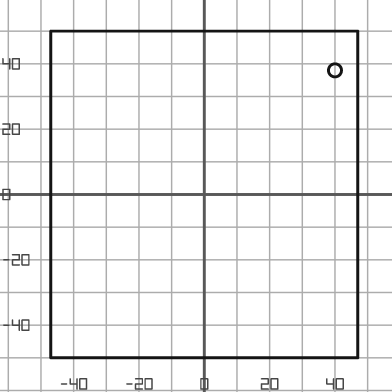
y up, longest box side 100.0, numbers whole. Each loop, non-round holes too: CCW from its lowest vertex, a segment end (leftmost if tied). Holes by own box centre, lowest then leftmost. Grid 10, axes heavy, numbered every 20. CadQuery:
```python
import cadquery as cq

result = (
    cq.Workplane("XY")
    .moveTo(-47.0, -50.0)
    .lineTo(47.0, -50.0)
    .lineTo(47.0, 50.0)
    .lineTo(-47.0, 50.0)
    .close()
    .moveTo(40.0, 38.0)
    .circle(2.0)
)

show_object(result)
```